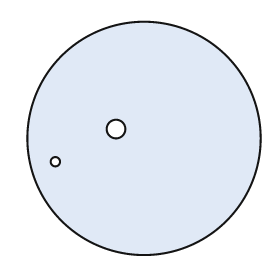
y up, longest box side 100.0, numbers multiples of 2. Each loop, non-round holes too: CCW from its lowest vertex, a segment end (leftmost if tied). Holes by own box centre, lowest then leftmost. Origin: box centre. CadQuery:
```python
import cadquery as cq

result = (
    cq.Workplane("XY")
    .moveTo(0.0, 0.0)
    .circle(50.0)
    .moveTo(-38.0, -10.0)
    .circle(2.0)
    .moveTo(-12.0, 4.0)
    .circle(4.0)
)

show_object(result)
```